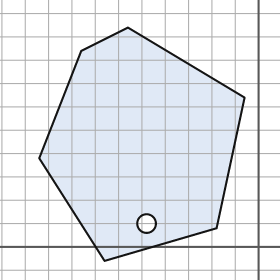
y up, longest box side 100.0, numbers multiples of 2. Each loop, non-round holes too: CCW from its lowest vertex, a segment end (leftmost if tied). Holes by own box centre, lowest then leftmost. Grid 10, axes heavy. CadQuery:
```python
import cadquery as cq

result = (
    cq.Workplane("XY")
    .moveTo(-66.0, -6.0)
    .lineTo(-18.0, 8.0)
    .lineTo(-6.0, 64.0)
    .lineTo(-56.0, 94.0)
    .lineTo(-76.0, 84.0)
    .lineTo(-94.0, 38.0)
    .close()
    .moveTo(-48.0, 10.0)
    .circle(4.0)
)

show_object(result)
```